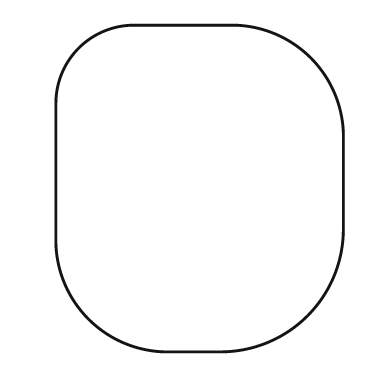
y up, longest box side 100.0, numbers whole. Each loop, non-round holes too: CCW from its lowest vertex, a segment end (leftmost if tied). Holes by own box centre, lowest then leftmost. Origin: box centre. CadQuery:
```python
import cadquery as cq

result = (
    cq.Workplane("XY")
    .moveTo(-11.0, -50.0)
    .lineTo(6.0, -50.0)
    .threePointArc((33.0, -39.0), (44.0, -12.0))
    .lineTo(44.0, 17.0)
    .threePointArc((34.0, 40.0), (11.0, 50.0))
    .lineTo(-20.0, 50.0)
    .threePointArc((-37.0, 43.0), (-44.0, 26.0))
    .lineTo(-44.0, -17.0)
    .threePointArc((-34.0, -40.0), (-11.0, -50.0))
    .close()
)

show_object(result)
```